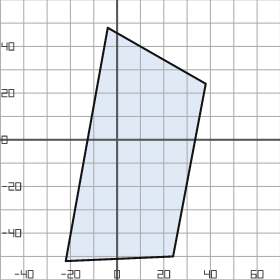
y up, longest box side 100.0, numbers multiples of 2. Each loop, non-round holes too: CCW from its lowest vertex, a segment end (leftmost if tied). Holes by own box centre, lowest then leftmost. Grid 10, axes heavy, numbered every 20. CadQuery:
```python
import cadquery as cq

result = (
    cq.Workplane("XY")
    .moveTo(-22.0, -52.0)
    .lineTo(24.0, -50.0)
    .lineTo(38.0, 24.0)
    .lineTo(-4.0, 48.0)
    .close()
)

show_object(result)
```